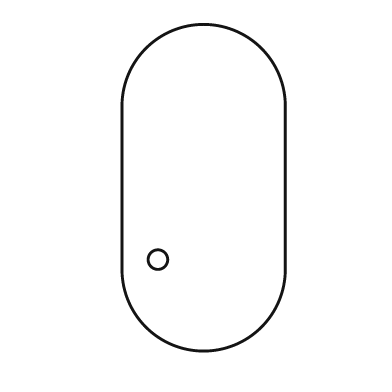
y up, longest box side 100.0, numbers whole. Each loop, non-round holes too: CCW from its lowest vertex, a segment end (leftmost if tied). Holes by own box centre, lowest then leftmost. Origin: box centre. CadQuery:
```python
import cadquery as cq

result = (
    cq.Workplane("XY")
    .moveTo(-25.0, -25.0)
    .threePointArc((0.0, -50.0), (25.0, -25.0))
    .lineTo(25.0, 25.0)
    .threePointArc((0.0, 50.0), (-25.0, 25.0))
    .close()
    .moveTo(-14.0, -22.0)
    .circle(3.0)
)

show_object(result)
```